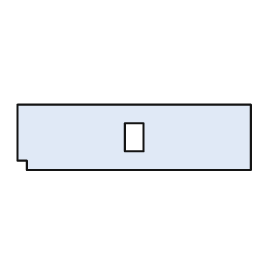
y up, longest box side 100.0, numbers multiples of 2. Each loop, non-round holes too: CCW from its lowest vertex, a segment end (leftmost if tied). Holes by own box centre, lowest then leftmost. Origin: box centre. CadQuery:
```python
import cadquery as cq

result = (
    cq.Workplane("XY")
    .moveTo(-46.0, -14.0)
    .lineTo(50.0, -14.0)
    .lineTo(50.0, 14.0)
    .lineTo(-50.0, 14.0)
    .lineTo(-50.0, -10.0)
    .lineTo(-46.0, -10.0)
    .close()
    .moveTo(-4.0, -6.0)
    .lineTo(4.0, -6.0)
    .lineTo(4.0, 6.0)
    .lineTo(-4.0, 6.0)
    .close()
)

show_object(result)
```